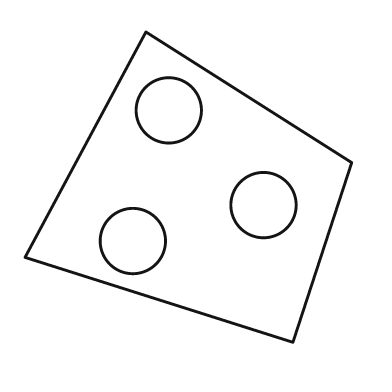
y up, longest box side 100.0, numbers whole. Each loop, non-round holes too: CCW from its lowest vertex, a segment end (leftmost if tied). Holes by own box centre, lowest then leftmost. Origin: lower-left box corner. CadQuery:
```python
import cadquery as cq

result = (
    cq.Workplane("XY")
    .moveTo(82.0, 0.0)
    .lineTo(100.0, 55.0)
    .lineTo(37.0, 95.0)
    .lineTo(0.0, 26.0)
    .close()
    .moveTo(33.0, 31.0)
    .circle(10.0)
    .moveTo(73.0, 42.0)
    .circle(10.0)
    .moveTo(44.0, 71.0)
    .circle(10.0)
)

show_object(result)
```